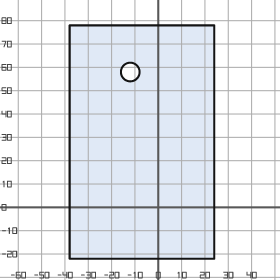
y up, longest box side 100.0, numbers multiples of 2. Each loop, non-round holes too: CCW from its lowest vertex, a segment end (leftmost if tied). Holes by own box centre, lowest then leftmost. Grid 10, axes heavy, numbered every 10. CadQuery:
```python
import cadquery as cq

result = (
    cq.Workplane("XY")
    .moveTo(-38.0, -22.0)
    .lineTo(24.0, -22.0)
    .lineTo(24.0, 78.0)
    .lineTo(-38.0, 78.0)
    .close()
    .moveTo(-12.0, 58.0)
    .circle(4.0)
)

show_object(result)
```